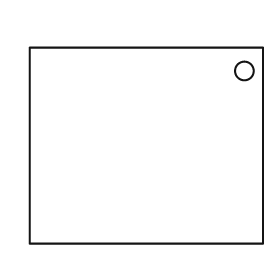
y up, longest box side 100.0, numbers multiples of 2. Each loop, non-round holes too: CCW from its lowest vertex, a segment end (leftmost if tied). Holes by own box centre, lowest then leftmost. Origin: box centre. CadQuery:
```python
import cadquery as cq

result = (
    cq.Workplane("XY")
    .moveTo(-50.0, -42.0)
    .lineTo(50.0, -42.0)
    .lineTo(50.0, 42.0)
    .lineTo(-50.0, 42.0)
    .close()
    .moveTo(42.0, 32.0)
    .circle(4.0)
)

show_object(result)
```